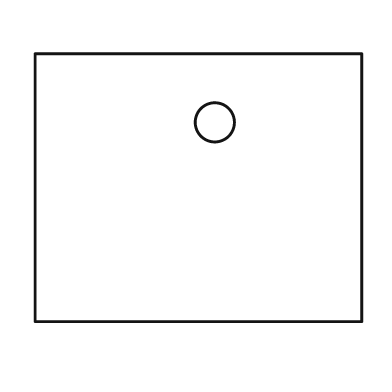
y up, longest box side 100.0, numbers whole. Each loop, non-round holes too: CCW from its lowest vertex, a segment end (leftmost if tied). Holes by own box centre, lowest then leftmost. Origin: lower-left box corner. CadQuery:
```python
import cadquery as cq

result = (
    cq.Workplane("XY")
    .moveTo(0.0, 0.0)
    .lineTo(100.0, 0.0)
    .lineTo(100.0, 82.0)
    .lineTo(0.0, 82.0)
    .close()
    .moveTo(55.0, 61.0)
    .circle(6.0)
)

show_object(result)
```